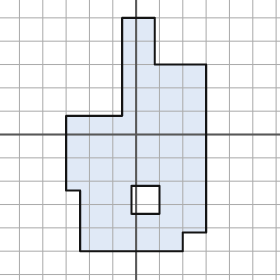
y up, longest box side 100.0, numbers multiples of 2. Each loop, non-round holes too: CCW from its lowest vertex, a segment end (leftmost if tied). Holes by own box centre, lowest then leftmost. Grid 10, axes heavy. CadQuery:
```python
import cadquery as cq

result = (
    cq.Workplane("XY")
    .moveTo(-24.0, -50.0)
    .lineTo(20.0, -50.0)
    .lineTo(20.0, -42.0)
    .lineTo(30.0, -42.0)
    .lineTo(30.0, 30.0)
    .lineTo(8.0, 30.0)
    .lineTo(8.0, 50.0)
    .lineTo(-6.0, 50.0)
    .lineTo(-6.0, 8.0)
    .lineTo(-30.0, 8.0)
    .lineTo(-30.0, -24.0)
    .lineTo(-24.0, -24.0)
    .close()
    .moveTo(-2.0, -34.0)
    .lineTo(10.0, -34.0)
    .lineTo(10.0, -22.0)
    .lineTo(-2.0, -22.0)
    .close()
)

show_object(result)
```